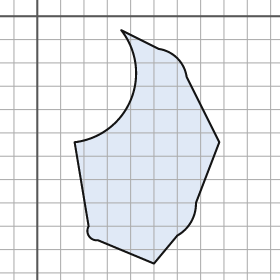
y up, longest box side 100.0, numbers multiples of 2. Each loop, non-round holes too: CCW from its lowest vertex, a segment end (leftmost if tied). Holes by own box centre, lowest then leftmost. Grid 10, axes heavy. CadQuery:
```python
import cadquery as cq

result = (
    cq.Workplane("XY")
    .moveTo(50.0, -106.0)
    .lineTo(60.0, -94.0)
    .threePointArc((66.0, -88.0), (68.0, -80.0))
    .lineTo(78.0, -54.0)
    .lineTo(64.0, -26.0)
    .threePointArc((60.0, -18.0), (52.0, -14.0))
    .lineTo(36.0, -6.0)
    .threePointArc((40.0, -36.0), (16.0, -54.0))
    .lineTo(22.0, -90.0)
    .threePointArc((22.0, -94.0), (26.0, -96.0))
    .close()
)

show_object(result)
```